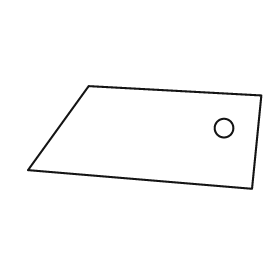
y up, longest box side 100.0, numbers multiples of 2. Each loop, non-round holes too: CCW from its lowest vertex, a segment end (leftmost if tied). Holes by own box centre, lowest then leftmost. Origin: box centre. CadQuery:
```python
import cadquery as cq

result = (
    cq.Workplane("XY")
    .moveTo(46.0, -22.0)
    .lineTo(50.0, 18.0)
    .lineTo(-24.0, 22.0)
    .lineTo(-50.0, -14.0)
    .close()
    .moveTo(34.0, 4.0)
    .circle(4.0)
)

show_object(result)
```